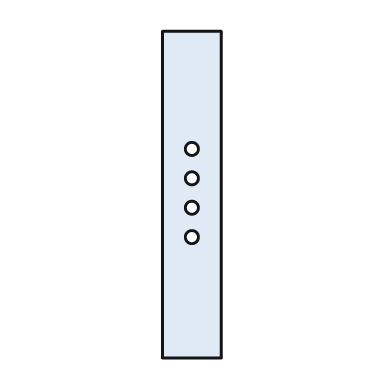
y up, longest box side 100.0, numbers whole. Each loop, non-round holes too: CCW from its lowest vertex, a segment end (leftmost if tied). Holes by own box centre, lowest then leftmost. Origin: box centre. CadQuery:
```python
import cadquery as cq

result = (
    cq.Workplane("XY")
    .moveTo(-9.0, -50.0)
    .lineTo(9.0, -50.0)
    .lineTo(9.0, 50.0)
    .lineTo(-9.0, 50.0)
    .close()
    .moveTo(0.0, -13.0)
    .circle(2.0)
    .moveTo(0.0, -4.0)
    .circle(2.0)
    .moveTo(0.0, 5.0)
    .circle(2.0)
    .moveTo(0.0, 14.0)
    .circle(2.0)
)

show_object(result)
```